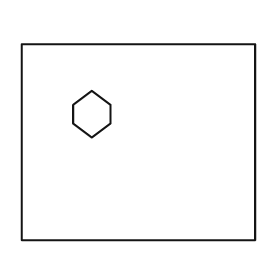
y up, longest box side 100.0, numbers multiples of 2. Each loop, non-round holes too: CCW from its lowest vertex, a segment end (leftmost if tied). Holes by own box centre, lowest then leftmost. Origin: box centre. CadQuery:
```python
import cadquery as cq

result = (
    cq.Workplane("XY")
    .moveTo(-50.0, -42.0)
    .lineTo(50.0, -42.0)
    .lineTo(50.0, 42.0)
    .lineTo(-50.0, 42.0)
    .close()
    .moveTo(-20.0, 2.0)
    .lineTo(-12.0, 8.0)
    .lineTo(-12.0, 16.0)
    .lineTo(-20.0, 22.0)
    .lineTo(-28.0, 16.0)
    .lineTo(-28.0, 8.0)
    .close()
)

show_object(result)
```